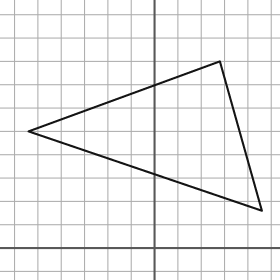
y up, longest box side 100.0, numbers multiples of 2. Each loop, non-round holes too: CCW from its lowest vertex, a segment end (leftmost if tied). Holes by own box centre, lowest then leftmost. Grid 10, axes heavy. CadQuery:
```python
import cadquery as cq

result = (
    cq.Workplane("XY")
    .moveTo(46.0, 16.0)
    .lineTo(28.0, 80.0)
    .lineTo(-54.0, 50.0)
    .close()
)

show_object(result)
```